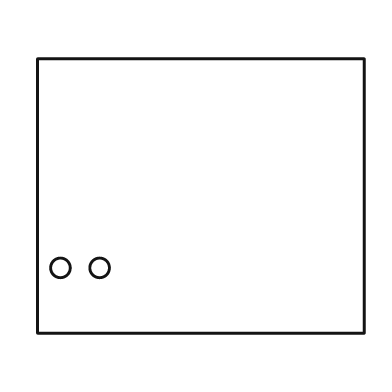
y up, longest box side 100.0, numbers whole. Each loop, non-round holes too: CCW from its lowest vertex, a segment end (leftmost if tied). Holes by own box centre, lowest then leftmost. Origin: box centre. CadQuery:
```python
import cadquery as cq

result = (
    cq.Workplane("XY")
    .moveTo(-50.0, -42.0)
    .lineTo(50.0, -42.0)
    .lineTo(50.0, 42.0)
    .lineTo(-50.0, 42.0)
    .close()
    .moveTo(-43.0, -22.0)
    .circle(3.0)
    .moveTo(-31.0, -22.0)
    .circle(3.0)
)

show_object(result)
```